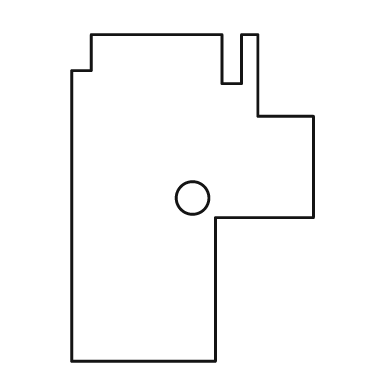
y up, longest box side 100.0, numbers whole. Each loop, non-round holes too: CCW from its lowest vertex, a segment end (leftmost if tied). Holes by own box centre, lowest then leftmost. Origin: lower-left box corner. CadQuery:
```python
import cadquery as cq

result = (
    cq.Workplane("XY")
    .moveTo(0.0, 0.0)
    .lineTo(44.0, 0.0)
    .lineTo(44.0, 44.0)
    .lineTo(74.0, 44.0)
    .lineTo(74.0, 75.0)
    .lineTo(57.0, 75.0)
    .lineTo(57.0, 100.0)
    .lineTo(52.0, 100.0)
    .lineTo(52.0, 85.0)
    .lineTo(46.0, 85.0)
    .lineTo(46.0, 100.0)
    .lineTo(6.0, 100.0)
    .lineTo(6.0, 89.0)
    .lineTo(0.0, 89.0)
    .close()
    .moveTo(37.0, 50.0)
    .circle(5.0)
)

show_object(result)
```